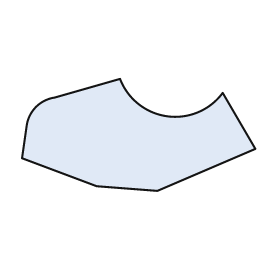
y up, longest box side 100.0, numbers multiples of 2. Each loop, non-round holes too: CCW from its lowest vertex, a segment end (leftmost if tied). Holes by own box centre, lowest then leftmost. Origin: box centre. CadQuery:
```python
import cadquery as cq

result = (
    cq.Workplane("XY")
    .moveTo(8.0, -24.0)
    .lineTo(50.0, -6.0)
    .lineTo(36.0, 18.0)
    .threePointArc((12.0, 8.0), (-8.0, 24.0))
    .lineTo(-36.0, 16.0)
    .threePointArc((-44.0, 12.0), (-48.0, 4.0))
    .lineTo(-50.0, -10.0)
    .lineTo(-18.0, -22.0)
    .close()
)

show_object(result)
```